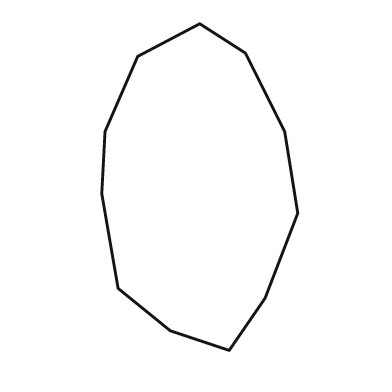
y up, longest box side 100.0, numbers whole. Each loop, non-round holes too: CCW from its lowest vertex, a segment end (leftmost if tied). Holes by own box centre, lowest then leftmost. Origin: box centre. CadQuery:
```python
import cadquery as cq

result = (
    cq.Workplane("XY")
    .moveTo(9.0, -50.0)
    .lineTo(20.0, -34.0)
    .lineTo(30.0, -8.0)
    .lineTo(26.0, 17.0)
    .lineTo(14.0, 41.0)
    .lineTo(0.0, 50.0)
    .lineTo(-19.0, 40.0)
    .lineTo(-29.0, 17.0)
    .lineTo(-30.0, -2.0)
    .lineTo(-25.0, -31.0)
    .lineTo(-9.0, -44.0)
    .close()
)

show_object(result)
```